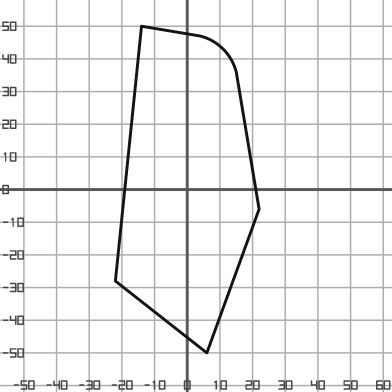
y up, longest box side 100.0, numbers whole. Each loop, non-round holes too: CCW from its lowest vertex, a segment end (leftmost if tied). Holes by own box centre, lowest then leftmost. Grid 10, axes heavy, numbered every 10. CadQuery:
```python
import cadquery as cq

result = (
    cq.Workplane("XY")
    .moveTo(6.0, -50.0)
    .lineTo(22.0, -6.0)
    .lineTo(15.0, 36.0)
    .threePointArc((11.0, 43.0), (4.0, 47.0))
    .lineTo(-14.0, 50.0)
    .lineTo(-22.0, -28.0)
    .close()
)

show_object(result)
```